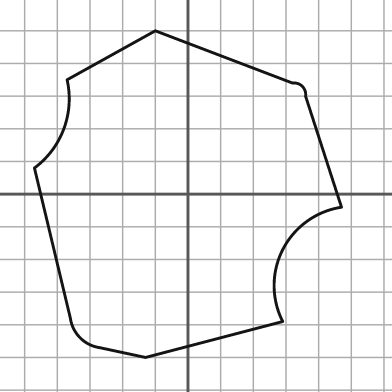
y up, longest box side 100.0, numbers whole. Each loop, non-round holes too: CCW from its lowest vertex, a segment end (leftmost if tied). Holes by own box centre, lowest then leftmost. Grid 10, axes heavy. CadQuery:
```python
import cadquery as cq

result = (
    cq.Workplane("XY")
    .moveTo(-13.0, -50.0)
    .lineTo(29.0, -39.0)
    .threePointArc((29.0, -17.0), (47.0, -4.0))
    .lineTo(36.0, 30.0)
    .threePointArc((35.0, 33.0), (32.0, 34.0))
    .lineTo(-10.0, 50.0)
    .lineTo(-37.0, 35.0)
    .threePointArc((-38.0, 20.0), (-47.0, 8.0))
    .lineTo(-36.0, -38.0)
    .threePointArc((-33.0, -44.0), (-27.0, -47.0))
    .close()
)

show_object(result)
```